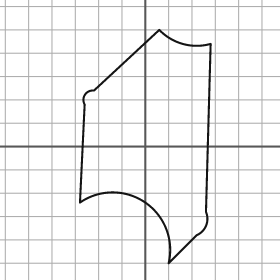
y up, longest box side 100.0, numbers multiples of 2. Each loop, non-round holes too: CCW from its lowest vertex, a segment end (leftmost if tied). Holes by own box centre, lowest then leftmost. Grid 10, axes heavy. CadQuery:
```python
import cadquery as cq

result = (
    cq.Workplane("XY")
    .moveTo(10.0, -50.0)
    .lineTo(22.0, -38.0)
    .threePointArc((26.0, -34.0), (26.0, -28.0))
    .lineTo(28.0, 44.0)
    .threePointArc((16.0, 44.0), (6.0, 50.0))
    .lineTo(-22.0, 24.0)
    .threePointArc((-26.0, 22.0), (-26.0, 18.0))
    .lineTo(-28.0, -24.0)
    .threePointArc((0.0, -24.0), (10.0, -50.0))
    .close()
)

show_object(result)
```